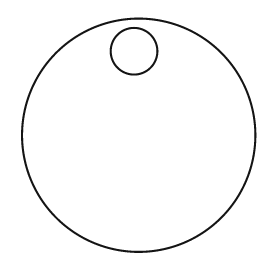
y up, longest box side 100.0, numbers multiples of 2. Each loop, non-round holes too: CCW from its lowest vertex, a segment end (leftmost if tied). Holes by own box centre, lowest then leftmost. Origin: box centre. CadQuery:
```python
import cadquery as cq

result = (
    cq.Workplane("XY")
    .moveTo(0.0, 0.0)
    .circle(50.0)
    .moveTo(-2.0, 36.0)
    .circle(10.0)
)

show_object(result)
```